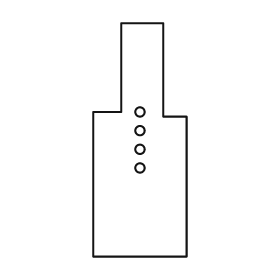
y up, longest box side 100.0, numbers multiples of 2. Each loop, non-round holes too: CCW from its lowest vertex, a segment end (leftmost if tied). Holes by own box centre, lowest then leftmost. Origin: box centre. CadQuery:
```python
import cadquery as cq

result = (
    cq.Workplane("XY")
    .moveTo(-20.0, -50.0)
    .lineTo(20.0, -50.0)
    .lineTo(20.0, 10.0)
    .lineTo(10.0, 10.0)
    .lineTo(10.0, 50.0)
    .lineTo(-8.0, 50.0)
    .lineTo(-8.0, 12.0)
    .lineTo(-20.0, 12.0)
    .close()
    .moveTo(0.0, -12.0)
    .circle(2.0)
    .moveTo(0.0, -4.0)
    .circle(2.0)
    .moveTo(0.0, 4.0)
    .circle(2.0)
    .moveTo(0.0, 12.0)
    .circle(2.0)
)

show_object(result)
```